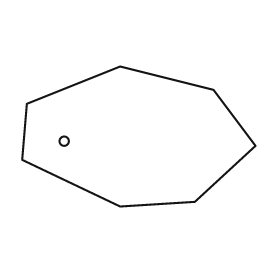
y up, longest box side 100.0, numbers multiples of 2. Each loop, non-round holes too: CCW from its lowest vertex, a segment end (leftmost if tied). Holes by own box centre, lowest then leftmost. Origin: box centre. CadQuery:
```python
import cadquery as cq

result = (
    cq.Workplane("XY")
    .moveTo(-8.0, -30.0)
    .lineTo(24.0, -28.0)
    .lineTo(50.0, -4.0)
    .lineTo(32.0, 20.0)
    .lineTo(-8.0, 30.0)
    .lineTo(-48.0, 14.0)
    .lineTo(-50.0, -10.0)
    .close()
    .moveTo(-32.0, -2.0)
    .circle(2.0)
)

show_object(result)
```